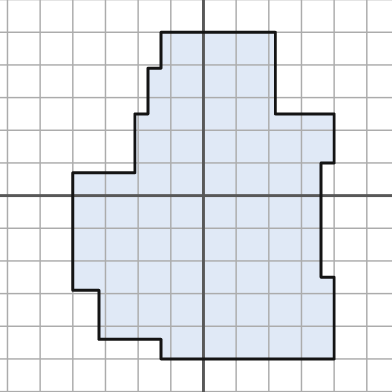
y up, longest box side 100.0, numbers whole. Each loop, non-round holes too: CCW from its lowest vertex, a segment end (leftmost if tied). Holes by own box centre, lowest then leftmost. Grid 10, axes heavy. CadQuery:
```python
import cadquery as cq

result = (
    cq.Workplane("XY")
    .moveTo(-13.0, -50.0)
    .lineTo(40.0, -50.0)
    .lineTo(40.0, -25.0)
    .lineTo(36.0, -25.0)
    .lineTo(36.0, 10.0)
    .lineTo(40.0, 10.0)
    .lineTo(40.0, 25.0)
    .lineTo(22.0, 25.0)
    .lineTo(22.0, 50.0)
    .lineTo(-13.0, 50.0)
    .lineTo(-13.0, 39.0)
    .lineTo(-17.0, 39.0)
    .lineTo(-17.0, 25.0)
    .lineTo(-21.0, 25.0)
    .lineTo(-21.0, 7.0)
    .lineTo(-40.0, 7.0)
    .lineTo(-40.0, -29.0)
    .lineTo(-32.0, -29.0)
    .lineTo(-32.0, -44.0)
    .lineTo(-13.0, -44.0)
    .close()
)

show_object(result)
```